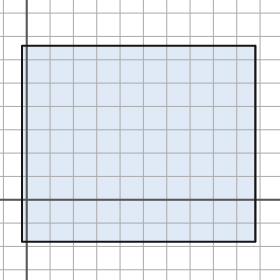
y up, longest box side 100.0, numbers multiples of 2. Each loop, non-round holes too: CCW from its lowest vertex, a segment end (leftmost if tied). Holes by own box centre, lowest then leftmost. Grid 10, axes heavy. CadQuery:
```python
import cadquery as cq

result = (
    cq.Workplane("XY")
    .moveTo(-2.0, -18.0)
    .lineTo(98.0, -18.0)
    .lineTo(98.0, 66.0)
    .lineTo(-2.0, 66.0)
    .close()
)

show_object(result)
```